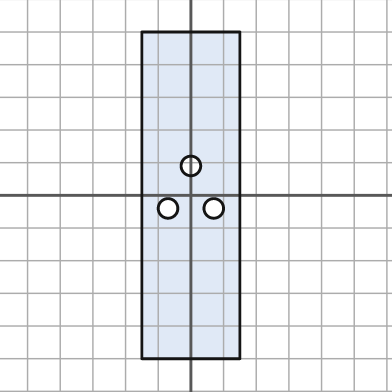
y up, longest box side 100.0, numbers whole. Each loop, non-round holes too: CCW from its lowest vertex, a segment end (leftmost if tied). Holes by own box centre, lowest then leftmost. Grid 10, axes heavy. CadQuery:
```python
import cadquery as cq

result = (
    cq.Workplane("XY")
    .moveTo(-15.0, -50.0)
    .lineTo(15.0, -50.0)
    .lineTo(15.0, 50.0)
    .lineTo(-15.0, 50.0)
    .close()
    .moveTo(-7.0, -4.0)
    .circle(3.0)
    .moveTo(7.0, -4.0)
    .circle(3.0)
    .moveTo(0.0, 9.0)
    .circle(3.0)
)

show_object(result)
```